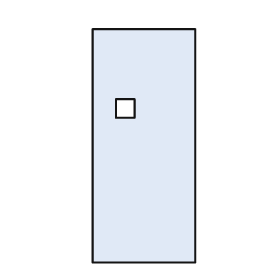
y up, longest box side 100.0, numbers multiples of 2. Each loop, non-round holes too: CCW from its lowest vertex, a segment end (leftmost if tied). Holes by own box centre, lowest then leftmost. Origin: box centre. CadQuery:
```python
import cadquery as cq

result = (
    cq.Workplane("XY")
    .moveTo(-22.0, -50.0)
    .lineTo(22.0, -50.0)
    .lineTo(22.0, 50.0)
    .lineTo(-22.0, 50.0)
    .close()
    .moveTo(-12.0, 12.0)
    .lineTo(-4.0, 12.0)
    .lineTo(-4.0, 20.0)
    .lineTo(-12.0, 20.0)
    .close()
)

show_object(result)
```